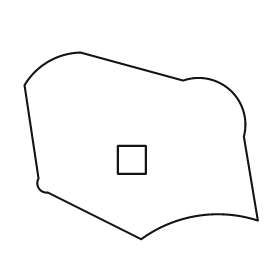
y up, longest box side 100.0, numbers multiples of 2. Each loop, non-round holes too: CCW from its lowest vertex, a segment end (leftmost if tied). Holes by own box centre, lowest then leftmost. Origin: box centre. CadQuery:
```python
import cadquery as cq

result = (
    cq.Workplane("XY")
    .moveTo(0.0, -40.0)
    .threePointArc((24.0, -30.0), (50.0, -32.0))
    .lineTo(44.0, 4.0)
    .threePointArc((38.0, 24.0), (18.0, 28.0))
    .lineTo(-26.0, 40.0)
    .threePointArc((-40.0, 36.0), (-50.0, 26.0))
    .lineTo(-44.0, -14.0)
    .threePointArc((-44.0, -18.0), (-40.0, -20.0))
    .close()
    .moveTo(-10.0, -12.0)
    .lineTo(2.0, -12.0)
    .lineTo(2.0, 0.0)
    .lineTo(-10.0, 0.0)
    .close()
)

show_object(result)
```